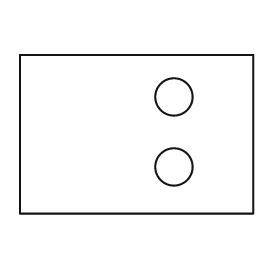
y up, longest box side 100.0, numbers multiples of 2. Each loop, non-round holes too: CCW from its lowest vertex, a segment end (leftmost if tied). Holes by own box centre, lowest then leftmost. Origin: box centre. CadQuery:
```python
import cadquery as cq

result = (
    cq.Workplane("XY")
    .moveTo(-50.0, -34.0)
    .lineTo(50.0, -34.0)
    .lineTo(50.0, 34.0)
    .lineTo(-50.0, 34.0)
    .close()
    .moveTo(16.0, -14.0)
    .circle(8.0)
    .moveTo(16.0, 16.0)
    .circle(8.0)
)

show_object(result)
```